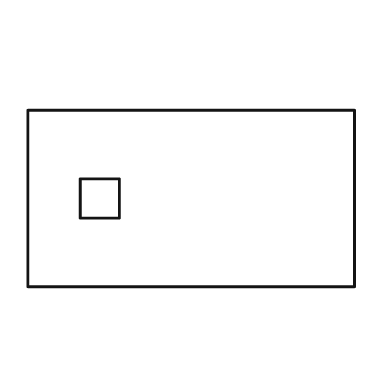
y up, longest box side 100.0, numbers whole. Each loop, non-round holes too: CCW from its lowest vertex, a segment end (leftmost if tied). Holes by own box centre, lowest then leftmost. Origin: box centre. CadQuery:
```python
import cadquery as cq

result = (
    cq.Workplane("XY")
    .moveTo(-50.0, -27.0)
    .lineTo(50.0, -27.0)
    .lineTo(50.0, 27.0)
    .lineTo(-50.0, 27.0)
    .close()
    .moveTo(-34.0, -6.0)
    .lineTo(-22.0, -6.0)
    .lineTo(-22.0, 6.0)
    .lineTo(-34.0, 6.0)
    .close()
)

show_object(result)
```